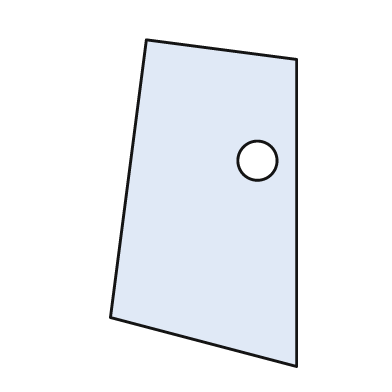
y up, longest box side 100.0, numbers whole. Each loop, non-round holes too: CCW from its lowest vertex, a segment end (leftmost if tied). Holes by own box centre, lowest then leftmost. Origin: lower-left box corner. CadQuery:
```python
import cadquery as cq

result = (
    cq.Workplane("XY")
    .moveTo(57.0, 0.0)
    .lineTo(57.0, 94.0)
    .lineTo(11.0, 100.0)
    .lineTo(0.0, 15.0)
    .close()
    .moveTo(45.0, 63.0)
    .circle(6.0)
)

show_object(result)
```